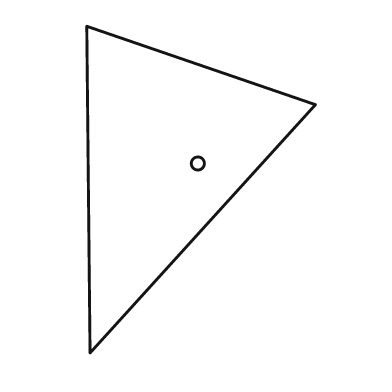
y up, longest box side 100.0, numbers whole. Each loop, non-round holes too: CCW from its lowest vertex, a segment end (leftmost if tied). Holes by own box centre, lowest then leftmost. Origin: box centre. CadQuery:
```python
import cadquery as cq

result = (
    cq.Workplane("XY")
    .moveTo(-34.0, -50.0)
    .lineTo(35.0, 26.0)
    .lineTo(-35.0, 50.0)
    .close()
    .moveTo(-1.0, 8.0)
    .circle(2.0)
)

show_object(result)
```